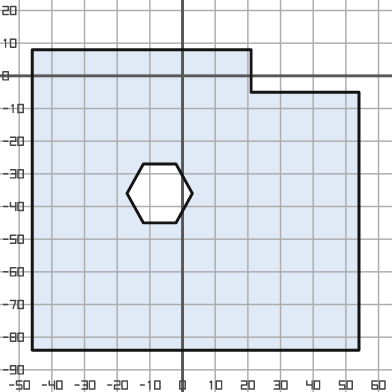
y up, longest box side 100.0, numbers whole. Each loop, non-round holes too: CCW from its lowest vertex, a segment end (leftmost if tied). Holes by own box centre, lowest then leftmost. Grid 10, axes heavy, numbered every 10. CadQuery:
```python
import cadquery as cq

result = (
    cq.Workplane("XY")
    .moveTo(-46.0, -84.0)
    .lineTo(54.0, -84.0)
    .lineTo(54.0, -5.0)
    .lineTo(21.0, -5.0)
    .lineTo(21.0, 8.0)
    .lineTo(-46.0, 8.0)
    .close()
    .moveTo(-12.0, -45.0)
    .lineTo(-2.0, -45.0)
    .lineTo(3.0, -36.0)
    .lineTo(-2.0, -27.0)
    .lineTo(-12.0, -27.0)
    .lineTo(-17.0, -36.0)
    .close()
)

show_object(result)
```